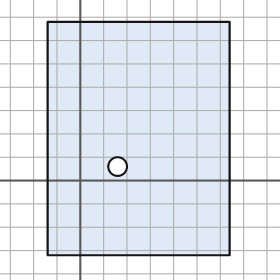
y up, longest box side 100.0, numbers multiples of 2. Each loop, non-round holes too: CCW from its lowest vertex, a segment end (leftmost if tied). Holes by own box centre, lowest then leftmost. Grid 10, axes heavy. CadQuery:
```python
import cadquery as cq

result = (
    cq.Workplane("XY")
    .moveTo(-14.0, -32.0)
    .lineTo(64.0, -32.0)
    .lineTo(64.0, 68.0)
    .lineTo(-14.0, 68.0)
    .close()
    .moveTo(16.0, 6.0)
    .circle(4.0)
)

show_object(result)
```